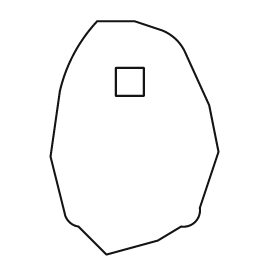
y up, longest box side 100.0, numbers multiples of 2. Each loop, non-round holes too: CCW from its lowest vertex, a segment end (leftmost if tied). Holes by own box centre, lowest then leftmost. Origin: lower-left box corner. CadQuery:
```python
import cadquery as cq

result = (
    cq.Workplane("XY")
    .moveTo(24.0, 0.0)
    .lineTo(46.0, 6.0)
    .lineTo(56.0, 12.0)
    .threePointArc((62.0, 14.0), (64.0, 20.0))
    .lineTo(72.0, 44.0)
    .lineTo(68.0, 64.0)
    .lineTo(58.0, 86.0)
    .threePointArc((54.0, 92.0), (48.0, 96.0))
    .lineTo(36.0, 100.0)
    .lineTo(20.0, 100.0)
    .threePointArc((10.0, 86.0), (4.0, 70.0))
    .lineTo(0.0, 42.0)
    .lineTo(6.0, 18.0)
    .threePointArc((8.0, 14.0), (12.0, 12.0))
    .close()
    .moveTo(28.0, 68.0)
    .lineTo(40.0, 68.0)
    .lineTo(40.0, 80.0)
    .lineTo(28.0, 80.0)
    .close()
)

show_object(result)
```